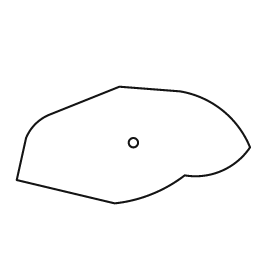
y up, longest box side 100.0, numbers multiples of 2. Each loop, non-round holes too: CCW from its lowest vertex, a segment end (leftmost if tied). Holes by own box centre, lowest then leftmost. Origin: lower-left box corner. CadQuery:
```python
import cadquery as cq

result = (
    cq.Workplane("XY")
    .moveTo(42.0, 0.0)
    .threePointArc((58.0, 4.0), (72.0, 12.0))
    .threePointArc((88.0, 14.0), (100.0, 24.0))
    .threePointArc((88.0, 40.0), (70.0, 48.0))
    .lineTo(44.0, 50.0)
    .lineTo(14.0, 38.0)
    .threePointArc((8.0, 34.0), (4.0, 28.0))
    .lineTo(0.0, 10.0)
    .close()
    .moveTo(50.0, 26.0)
    .circle(2.0)
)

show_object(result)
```